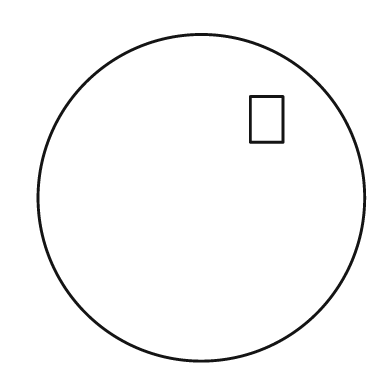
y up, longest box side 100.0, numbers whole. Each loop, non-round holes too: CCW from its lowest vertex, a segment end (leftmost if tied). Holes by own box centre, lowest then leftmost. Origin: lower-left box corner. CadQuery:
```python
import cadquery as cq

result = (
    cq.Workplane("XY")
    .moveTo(50.0, 50.0)
    .circle(50.0)
    .moveTo(65.0, 67.0)
    .lineTo(75.0, 67.0)
    .lineTo(75.0, 81.0)
    .lineTo(65.0, 81.0)
    .close()
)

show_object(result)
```